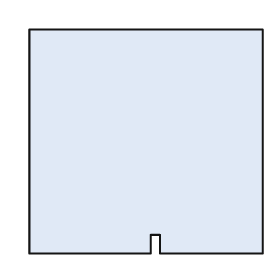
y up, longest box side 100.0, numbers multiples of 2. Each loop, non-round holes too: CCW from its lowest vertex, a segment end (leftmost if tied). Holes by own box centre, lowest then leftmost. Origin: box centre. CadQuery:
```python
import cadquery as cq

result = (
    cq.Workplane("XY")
    .moveTo(-50.0, -48.0)
    .lineTo(2.0, -48.0)
    .lineTo(2.0, -40.0)
    .lineTo(6.0, -40.0)
    .lineTo(6.0, -48.0)
    .lineTo(50.0, -48.0)
    .lineTo(50.0, 48.0)
    .lineTo(-50.0, 48.0)
    .close()
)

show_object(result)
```